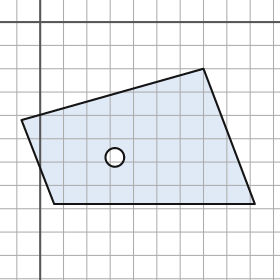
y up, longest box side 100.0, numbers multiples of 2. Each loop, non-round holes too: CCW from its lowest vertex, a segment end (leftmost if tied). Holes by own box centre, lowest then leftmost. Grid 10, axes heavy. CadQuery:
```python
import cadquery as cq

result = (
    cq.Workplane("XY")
    .moveTo(6.0, -78.0)
    .lineTo(92.0, -78.0)
    .lineTo(70.0, -20.0)
    .lineTo(-8.0, -42.0)
    .close()
    .moveTo(32.0, -58.0)
    .circle(4.0)
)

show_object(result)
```